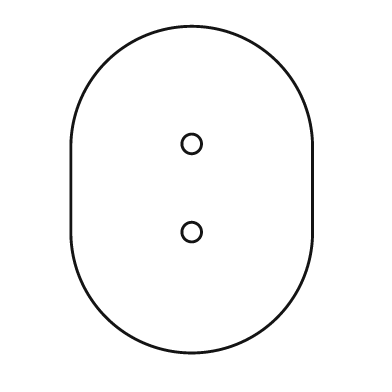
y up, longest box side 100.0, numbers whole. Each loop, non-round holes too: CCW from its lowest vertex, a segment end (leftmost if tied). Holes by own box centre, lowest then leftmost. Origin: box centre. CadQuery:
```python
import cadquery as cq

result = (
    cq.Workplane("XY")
    .moveTo(-37.0, -13.0)
    .threePointArc((0.0, -50.0), (37.0, -13.0))
    .lineTo(37.0, 13.0)
    .threePointArc((0.0, 50.0), (-37.0, 13.0))
    .close()
    .moveTo(0.0, -13.0)
    .circle(3.0)
    .moveTo(0.0, 14.0)
    .circle(3.0)
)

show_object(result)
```